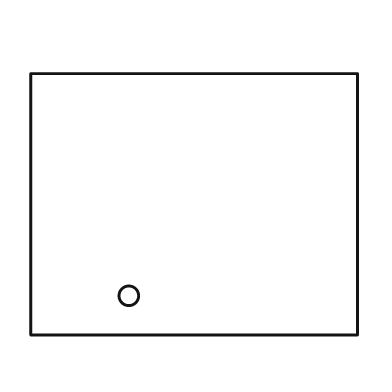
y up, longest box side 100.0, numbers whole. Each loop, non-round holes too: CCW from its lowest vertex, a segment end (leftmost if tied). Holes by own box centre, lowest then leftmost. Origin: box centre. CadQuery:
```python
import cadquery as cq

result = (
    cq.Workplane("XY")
    .moveTo(-50.0, -40.0)
    .lineTo(50.0, -40.0)
    .lineTo(50.0, 40.0)
    .lineTo(-50.0, 40.0)
    .close()
    .moveTo(-20.0, -28.0)
    .circle(3.0)
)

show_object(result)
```